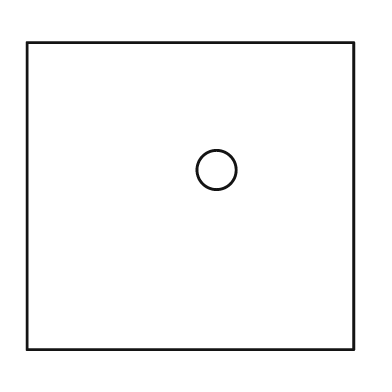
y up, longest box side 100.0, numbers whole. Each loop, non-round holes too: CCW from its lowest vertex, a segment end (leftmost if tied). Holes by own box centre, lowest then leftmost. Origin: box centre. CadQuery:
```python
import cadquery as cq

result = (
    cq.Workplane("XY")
    .moveTo(-50.0, -47.0)
    .lineTo(50.0, -47.0)
    .lineTo(50.0, 47.0)
    .lineTo(-50.0, 47.0)
    .close()
    .moveTo(8.0, 8.0)
    .circle(6.0)
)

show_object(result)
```